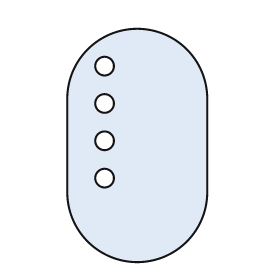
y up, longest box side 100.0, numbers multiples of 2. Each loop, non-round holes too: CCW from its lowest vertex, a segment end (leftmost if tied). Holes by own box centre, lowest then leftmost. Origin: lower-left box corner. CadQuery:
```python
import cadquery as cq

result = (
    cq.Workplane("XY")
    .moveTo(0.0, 30.0)
    .threePointArc((30.0, 0.0), (60.0, 30.0))
    .lineTo(60.0, 70.0)
    .threePointArc((30.0, 100.0), (0.0, 70.0))
    .close()
    .moveTo(16.0, 36.0)
    .circle(4.0)
    .moveTo(16.0, 52.0)
    .circle(4.0)
    .moveTo(16.0, 68.0)
    .circle(4.0)
    .moveTo(16.0, 84.0)
    .circle(4.0)
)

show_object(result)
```